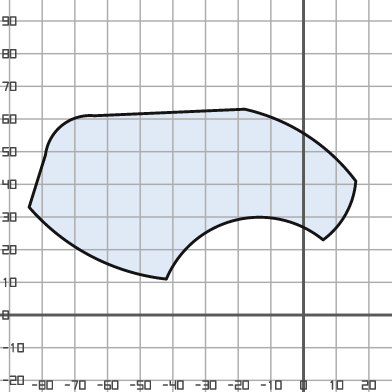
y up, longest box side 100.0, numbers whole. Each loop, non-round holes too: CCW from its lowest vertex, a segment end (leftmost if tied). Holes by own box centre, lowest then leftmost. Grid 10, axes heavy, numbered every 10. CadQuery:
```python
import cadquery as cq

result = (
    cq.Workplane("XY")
    .moveTo(-42.0, 11.0)
    .threePointArc((-21.0, 29.0), (6.0, 23.0))
    .threePointArc((13.0, 31.0), (16.0, 41.0))
    .threePointArc((1.0, 55.0), (-18.0, 63.0))
    .lineTo(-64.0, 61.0)
    .threePointArc((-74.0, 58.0), (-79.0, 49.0))
    .lineTo(-84.0, 33.0)
    .threePointArc((-65.0, 18.0), (-42.0, 11.0))
    .close()
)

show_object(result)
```